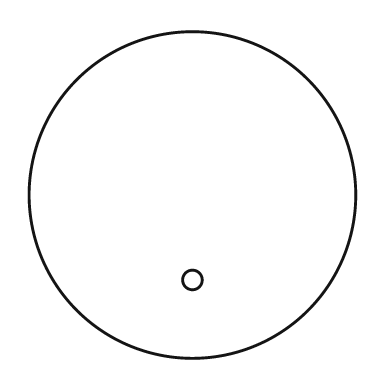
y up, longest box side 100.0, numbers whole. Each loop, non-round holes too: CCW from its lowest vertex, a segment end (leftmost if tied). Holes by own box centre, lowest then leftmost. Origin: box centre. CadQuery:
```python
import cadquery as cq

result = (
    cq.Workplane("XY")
    .moveTo(0.0, 0.0)
    .circle(50.0)
    .moveTo(0.0, -26.0)
    .circle(3.0)
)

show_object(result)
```